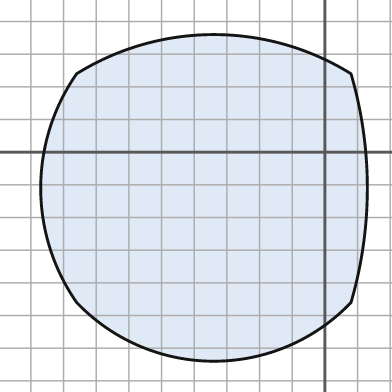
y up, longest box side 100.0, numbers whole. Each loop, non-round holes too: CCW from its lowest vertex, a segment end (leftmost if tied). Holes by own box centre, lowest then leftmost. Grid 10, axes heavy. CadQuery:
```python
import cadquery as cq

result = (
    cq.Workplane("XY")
    .moveTo(-76.0, -46.0)
    .threePointArc((-34.0, -64.0), (8.0, -46.0))
    .threePointArc((13.0, -11.0), (8.0, 24.0))
    .threePointArc((-34.0, 36.0), (-76.0, 24.0))
    .threePointArc((-87.0, -11.0), (-76.0, -46.0))
    .close()
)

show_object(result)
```